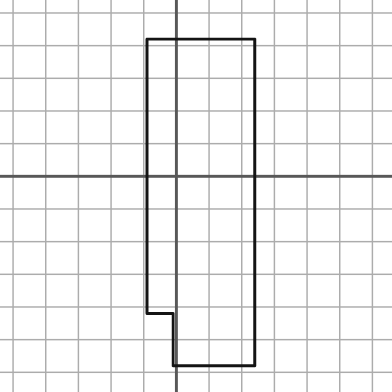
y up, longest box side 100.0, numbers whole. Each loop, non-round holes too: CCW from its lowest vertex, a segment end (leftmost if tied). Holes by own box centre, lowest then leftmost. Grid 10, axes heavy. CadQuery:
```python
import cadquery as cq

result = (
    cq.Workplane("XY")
    .moveTo(-1.0, -58.0)
    .lineTo(24.0, -58.0)
    .lineTo(24.0, 42.0)
    .lineTo(-9.0, 42.0)
    .lineTo(-9.0, -42.0)
    .lineTo(-1.0, -42.0)
    .close()
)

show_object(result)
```